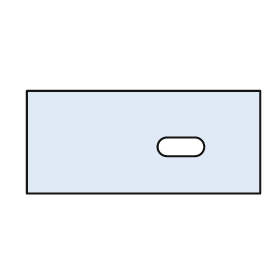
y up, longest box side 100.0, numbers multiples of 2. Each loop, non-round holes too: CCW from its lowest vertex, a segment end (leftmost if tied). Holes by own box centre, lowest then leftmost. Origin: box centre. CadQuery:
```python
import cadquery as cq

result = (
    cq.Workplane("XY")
    .moveTo(-50.0, -22.0)
    .lineTo(50.0, -22.0)
    .lineTo(50.0, 22.0)
    .lineTo(-50.0, 22.0)
    .close()
    .moveTo(10.0, -6.0)
    .lineTo(22.0, -6.0)
    .threePointArc((26.0, -2.0), (22.0, 2.0))
    .lineTo(10.0, 2.0)
    .threePointArc((6.0, -2.0), (10.0, -6.0))
    .close()
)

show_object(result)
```